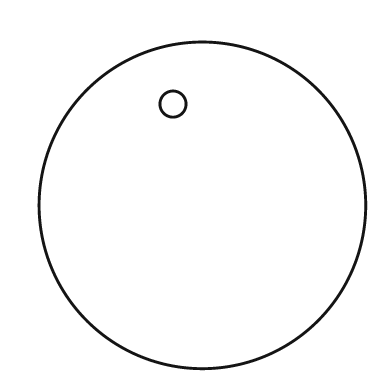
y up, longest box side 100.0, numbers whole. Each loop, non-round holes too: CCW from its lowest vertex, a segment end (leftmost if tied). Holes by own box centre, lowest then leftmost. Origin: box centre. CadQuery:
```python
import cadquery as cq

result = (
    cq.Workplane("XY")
    .moveTo(0.0, 0.0)
    .circle(50.0)
    .moveTo(-9.0, 31.0)
    .circle(4.0)
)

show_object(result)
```